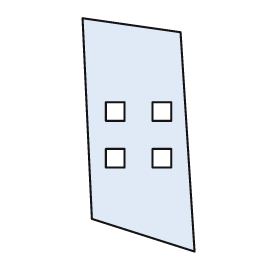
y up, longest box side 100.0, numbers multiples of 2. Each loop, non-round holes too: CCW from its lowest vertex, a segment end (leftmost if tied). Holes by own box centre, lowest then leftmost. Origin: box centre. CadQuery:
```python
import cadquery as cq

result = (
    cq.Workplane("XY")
    .moveTo(24.0, -50.0)
    .lineTo(18.0, 44.0)
    .lineTo(-24.0, 50.0)
    .lineTo(-20.0, -36.0)
    .close()
    .moveTo(-14.0, -14.0)
    .lineTo(-6.0, -14.0)
    .lineTo(-6.0, -6.0)
    .lineTo(-14.0, -6.0)
    .close()
    .moveTo(6.0, -14.0)
    .lineTo(14.0, -14.0)
    .lineTo(14.0, -6.0)
    .lineTo(6.0, -6.0)
    .close()
    .moveTo(-14.0, 6.0)
    .lineTo(-6.0, 6.0)
    .lineTo(-6.0, 14.0)
    .lineTo(-14.0, 14.0)
    .close()
    .moveTo(6.0, 6.0)
    .lineTo(14.0, 6.0)
    .lineTo(14.0, 14.0)
    .lineTo(6.0, 14.0)
    .close()
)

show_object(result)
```